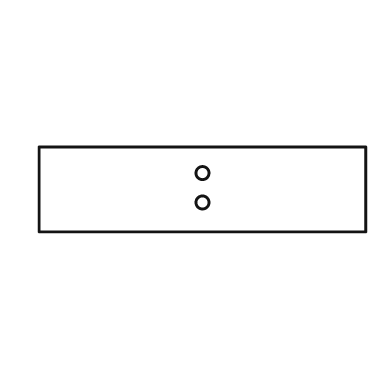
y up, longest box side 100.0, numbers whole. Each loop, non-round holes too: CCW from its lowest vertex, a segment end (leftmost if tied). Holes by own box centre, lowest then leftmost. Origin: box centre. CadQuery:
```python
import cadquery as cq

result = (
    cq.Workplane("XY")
    .moveTo(-50.0, -13.0)
    .lineTo(50.0, -13.0)
    .lineTo(50.0, 13.0)
    .lineTo(-50.0, 13.0)
    .close()
    .moveTo(0.0, -4.0)
    .circle(2.0)
    .moveTo(0.0, 5.0)
    .circle(2.0)
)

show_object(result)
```